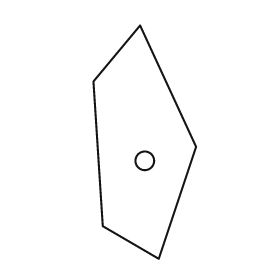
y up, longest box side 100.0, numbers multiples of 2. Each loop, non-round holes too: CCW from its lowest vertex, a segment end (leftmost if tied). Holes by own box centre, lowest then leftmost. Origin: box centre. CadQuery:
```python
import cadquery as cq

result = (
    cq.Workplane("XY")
    .moveTo(6.0, -50.0)
    .lineTo(22.0, -2.0)
    .lineTo(-2.0, 50.0)
    .lineTo(-22.0, 26.0)
    .lineTo(-18.0, -36.0)
    .close()
    .moveTo(0.0, -8.0)
    .circle(4.0)
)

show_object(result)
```